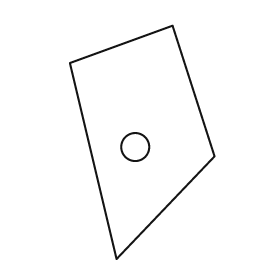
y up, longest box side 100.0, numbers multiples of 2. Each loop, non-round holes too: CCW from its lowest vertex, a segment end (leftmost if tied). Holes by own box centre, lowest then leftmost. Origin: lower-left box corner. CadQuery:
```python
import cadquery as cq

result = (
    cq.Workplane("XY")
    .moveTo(20.0, 0.0)
    .lineTo(62.0, 44.0)
    .lineTo(44.0, 100.0)
    .lineTo(0.0, 84.0)
    .close()
    .moveTo(28.0, 48.0)
    .circle(6.0)
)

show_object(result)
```